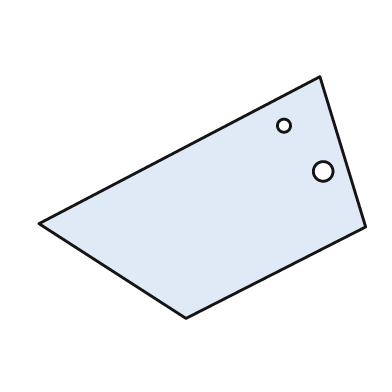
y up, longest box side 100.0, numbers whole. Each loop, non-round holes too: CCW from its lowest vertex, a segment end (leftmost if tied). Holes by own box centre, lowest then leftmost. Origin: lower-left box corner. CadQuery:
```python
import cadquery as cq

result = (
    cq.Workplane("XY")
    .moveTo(45.0, 0.0)
    .lineTo(100.0, 28.0)
    .lineTo(86.0, 74.0)
    .lineTo(0.0, 29.0)
    .close()
    .moveTo(87.0, 45.0)
    .circle(3.0)
    .moveTo(75.0, 59.0)
    .circle(2.0)
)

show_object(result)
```